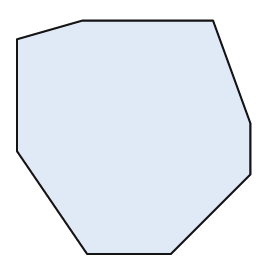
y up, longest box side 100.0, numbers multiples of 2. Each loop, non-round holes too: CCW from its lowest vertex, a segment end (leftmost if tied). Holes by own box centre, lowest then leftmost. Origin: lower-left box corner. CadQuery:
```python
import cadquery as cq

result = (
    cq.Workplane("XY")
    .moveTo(30.0, 0.0)
    .lineTo(66.0, 0.0)
    .lineTo(100.0, 34.0)
    .lineTo(100.0, 56.0)
    .lineTo(84.0, 100.0)
    .lineTo(28.0, 100.0)
    .lineTo(0.0, 92.0)
    .lineTo(0.0, 44.0)
    .close()
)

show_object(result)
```